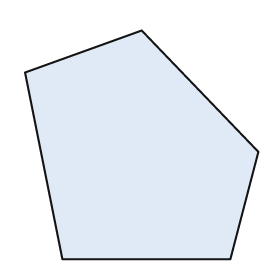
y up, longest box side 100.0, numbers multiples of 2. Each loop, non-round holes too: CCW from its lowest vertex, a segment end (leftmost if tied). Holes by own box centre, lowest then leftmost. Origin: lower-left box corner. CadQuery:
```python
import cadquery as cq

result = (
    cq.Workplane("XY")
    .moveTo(16.0, 0.0)
    .lineTo(88.0, 0.0)
    .lineTo(100.0, 46.0)
    .lineTo(50.0, 98.0)
    .lineTo(0.0, 80.0)
    .close()
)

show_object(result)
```